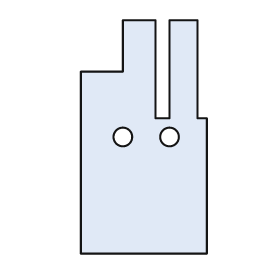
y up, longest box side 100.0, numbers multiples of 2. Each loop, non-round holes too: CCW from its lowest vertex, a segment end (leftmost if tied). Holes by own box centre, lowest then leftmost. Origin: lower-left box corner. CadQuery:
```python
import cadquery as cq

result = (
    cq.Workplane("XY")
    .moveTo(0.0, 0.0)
    .lineTo(54.0, 0.0)
    .lineTo(54.0, 58.0)
    .lineTo(50.0, 58.0)
    .lineTo(50.0, 100.0)
    .lineTo(38.0, 100.0)
    .lineTo(38.0, 58.0)
    .lineTo(32.0, 58.0)
    .lineTo(32.0, 100.0)
    .lineTo(18.0, 100.0)
    .lineTo(18.0, 78.0)
    .lineTo(0.0, 78.0)
    .close()
    .moveTo(18.0, 50.0)
    .circle(4.0)
    .moveTo(38.0, 50.0)
    .circle(4.0)
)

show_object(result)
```